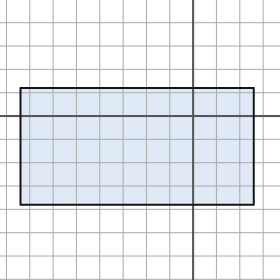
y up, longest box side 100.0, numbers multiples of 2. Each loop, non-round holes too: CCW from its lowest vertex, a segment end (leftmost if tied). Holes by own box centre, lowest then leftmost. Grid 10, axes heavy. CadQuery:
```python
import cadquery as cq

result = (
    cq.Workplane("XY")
    .moveTo(-74.0, -38.0)
    .lineTo(26.0, -38.0)
    .lineTo(26.0, 12.0)
    .lineTo(-74.0, 12.0)
    .close()
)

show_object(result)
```